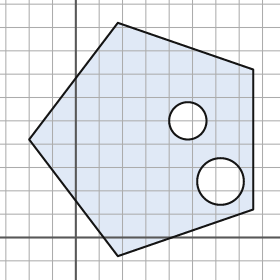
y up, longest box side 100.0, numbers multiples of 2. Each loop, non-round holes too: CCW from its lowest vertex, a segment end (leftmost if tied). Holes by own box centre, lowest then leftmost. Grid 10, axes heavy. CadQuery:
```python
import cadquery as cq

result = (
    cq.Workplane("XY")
    .moveTo(18.0, -8.0)
    .lineTo(76.0, 12.0)
    .lineTo(76.0, 72.0)
    .lineTo(18.0, 92.0)
    .lineTo(-20.0, 42.0)
    .close()
    .moveTo(62.0, 24.0)
    .circle(10.0)
    .moveTo(48.0, 50.0)
    .circle(8.0)
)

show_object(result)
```